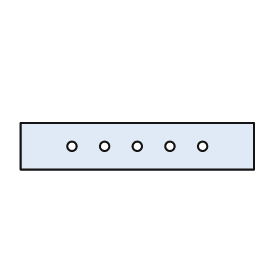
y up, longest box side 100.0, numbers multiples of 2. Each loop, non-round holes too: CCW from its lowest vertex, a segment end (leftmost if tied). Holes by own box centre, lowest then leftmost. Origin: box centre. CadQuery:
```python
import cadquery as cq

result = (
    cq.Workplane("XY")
    .moveTo(-50.0, -10.0)
    .lineTo(50.0, -10.0)
    .lineTo(50.0, 10.0)
    .lineTo(-50.0, 10.0)
    .close()
    .moveTo(-28.0, 0.0)
    .circle(2.0)
    .moveTo(-14.0, 0.0)
    .circle(2.0)
    .moveTo(0.0, 0.0)
    .circle(2.0)
    .moveTo(14.0, 0.0)
    .circle(2.0)
    .moveTo(28.0, 0.0)
    .circle(2.0)
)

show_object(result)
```